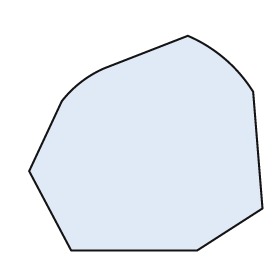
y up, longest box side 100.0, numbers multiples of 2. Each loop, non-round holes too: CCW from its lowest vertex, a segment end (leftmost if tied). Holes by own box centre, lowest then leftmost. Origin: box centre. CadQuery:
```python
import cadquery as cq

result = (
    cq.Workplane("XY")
    .moveTo(-32.0, -46.0)
    .lineTo(22.0, -46.0)
    .lineTo(50.0, -28.0)
    .lineTo(46.0, 22.0)
    .threePointArc((34.0, 36.0), (18.0, 46.0))
    .lineTo(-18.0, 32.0)
    .threePointArc((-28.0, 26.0), (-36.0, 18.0))
    .lineTo(-50.0, -12.0)
    .close()
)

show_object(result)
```